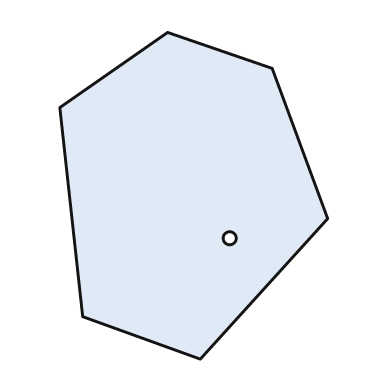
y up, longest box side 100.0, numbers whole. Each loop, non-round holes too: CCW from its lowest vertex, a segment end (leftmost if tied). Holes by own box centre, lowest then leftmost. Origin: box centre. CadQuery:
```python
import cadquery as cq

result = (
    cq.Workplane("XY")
    .moveTo(2.0, -50.0)
    .lineTo(41.0, -7.0)
    .lineTo(24.0, 39.0)
    .lineTo(-8.0, 50.0)
    .lineTo(-41.0, 27.0)
    .lineTo(-34.0, -37.0)
    .close()
    .moveTo(11.0, -13.0)
    .circle(2.0)
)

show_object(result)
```